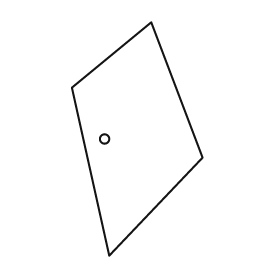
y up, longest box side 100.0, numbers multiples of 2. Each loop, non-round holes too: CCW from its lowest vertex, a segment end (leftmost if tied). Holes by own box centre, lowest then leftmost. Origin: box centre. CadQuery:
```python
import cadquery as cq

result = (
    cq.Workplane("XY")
    .moveTo(-12.0, -50.0)
    .lineTo(28.0, -8.0)
    .lineTo(6.0, 50.0)
    .lineTo(-28.0, 22.0)
    .close()
    .moveTo(-14.0, 0.0)
    .circle(2.0)
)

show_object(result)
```